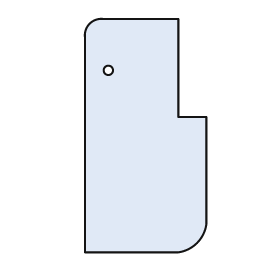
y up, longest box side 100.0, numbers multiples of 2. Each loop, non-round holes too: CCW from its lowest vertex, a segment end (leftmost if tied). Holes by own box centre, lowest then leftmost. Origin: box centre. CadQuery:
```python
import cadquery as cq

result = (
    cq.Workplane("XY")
    .moveTo(-26.0, -50.0)
    .lineTo(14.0, -50.0)
    .threePointArc((22.0, -46.0), (26.0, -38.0))
    .lineTo(26.0, 8.0)
    .lineTo(14.0, 8.0)
    .lineTo(14.0, 50.0)
    .lineTo(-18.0, 50.0)
    .threePointArc((-24.0, 48.0), (-26.0, 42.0))
    .close()
    .moveTo(-16.0, 28.0)
    .circle(2.0)
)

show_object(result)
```